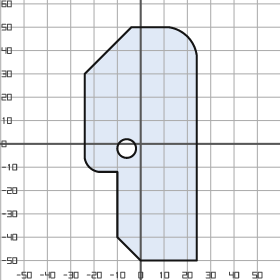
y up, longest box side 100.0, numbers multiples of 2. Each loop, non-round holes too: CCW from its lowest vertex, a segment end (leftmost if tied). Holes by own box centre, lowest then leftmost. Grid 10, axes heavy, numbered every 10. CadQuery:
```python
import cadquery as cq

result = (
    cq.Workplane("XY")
    .moveTo(0.0, -50.0)
    .lineTo(24.0, -50.0)
    .lineTo(24.0, 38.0)
    .threePointArc((20.0, 46.0), (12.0, 50.0))
    .lineTo(-4.0, 50.0)
    .lineTo(-24.0, 30.0)
    .lineTo(-24.0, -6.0)
    .threePointArc((-22.0, -10.0), (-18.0, -12.0))
    .lineTo(-10.0, -12.0)
    .lineTo(-10.0, -40.0)
    .close()
    .moveTo(-6.0, -2.0)
    .circle(4.0)
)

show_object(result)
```